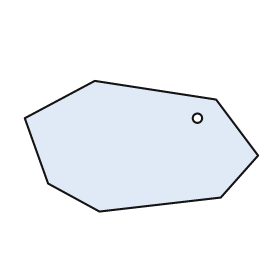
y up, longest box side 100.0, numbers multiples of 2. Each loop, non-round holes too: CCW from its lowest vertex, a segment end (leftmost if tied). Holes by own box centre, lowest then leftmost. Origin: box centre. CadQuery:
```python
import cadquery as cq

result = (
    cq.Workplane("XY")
    .moveTo(-18.0, -28.0)
    .lineTo(34.0, -22.0)
    .lineTo(50.0, -4.0)
    .lineTo(32.0, 20.0)
    .lineTo(-20.0, 28.0)
    .lineTo(-50.0, 12.0)
    .lineTo(-40.0, -16.0)
    .close()
    .moveTo(24.0, 12.0)
    .circle(2.0)
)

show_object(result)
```